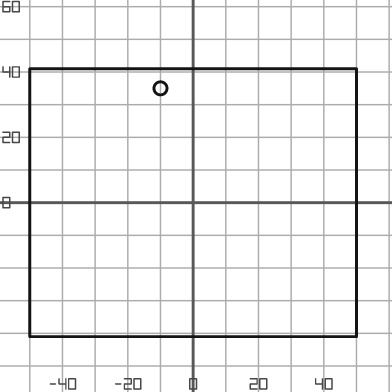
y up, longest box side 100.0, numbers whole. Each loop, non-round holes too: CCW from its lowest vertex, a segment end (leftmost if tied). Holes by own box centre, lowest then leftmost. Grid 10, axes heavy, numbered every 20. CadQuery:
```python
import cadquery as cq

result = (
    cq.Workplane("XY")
    .moveTo(-50.0, -41.0)
    .lineTo(50.0, -41.0)
    .lineTo(50.0, 41.0)
    .lineTo(-50.0, 41.0)
    .close()
    .moveTo(-10.0, 35.0)
    .circle(2.0)
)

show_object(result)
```